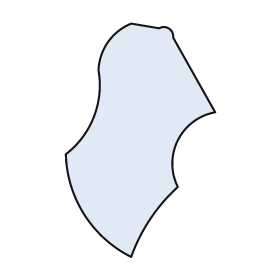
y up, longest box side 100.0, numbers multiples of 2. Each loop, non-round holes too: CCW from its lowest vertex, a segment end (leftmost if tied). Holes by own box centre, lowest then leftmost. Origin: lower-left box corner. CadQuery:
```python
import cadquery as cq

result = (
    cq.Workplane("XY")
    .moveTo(28.0, 0.0)
    .threePointArc((36.0, 16.0), (48.0, 30.0))
    .threePointArc((48.0, 50.0), (64.0, 62.0))
    .lineTo(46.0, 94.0)
    .threePointArc((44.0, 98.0), (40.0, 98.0))
    .lineTo(28.0, 100.0)
    .threePointArc((18.0, 92.0), (14.0, 80.0))
    .threePointArc((12.0, 60.0), (0.0, 44.0))
    .threePointArc((8.0, 18.0), (28.0, 0.0))
    .close()
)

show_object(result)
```